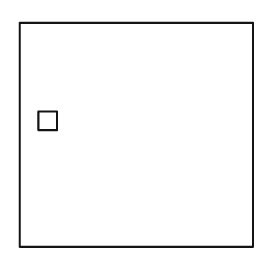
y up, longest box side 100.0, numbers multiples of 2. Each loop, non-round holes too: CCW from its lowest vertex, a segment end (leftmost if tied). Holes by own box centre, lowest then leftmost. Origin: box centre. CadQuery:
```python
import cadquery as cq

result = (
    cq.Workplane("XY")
    .moveTo(-50.0, -48.0)
    .lineTo(50.0, -48.0)
    .lineTo(50.0, 48.0)
    .lineTo(-50.0, 48.0)
    .close()
    .moveTo(-42.0, 2.0)
    .lineTo(-34.0, 2.0)
    .lineTo(-34.0, 10.0)
    .lineTo(-42.0, 10.0)
    .close()
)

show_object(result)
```